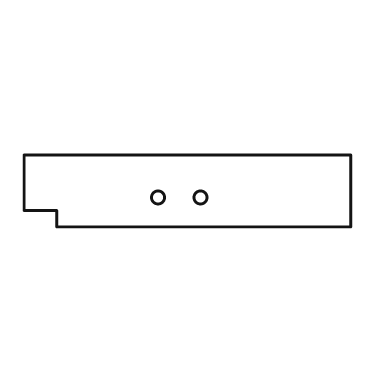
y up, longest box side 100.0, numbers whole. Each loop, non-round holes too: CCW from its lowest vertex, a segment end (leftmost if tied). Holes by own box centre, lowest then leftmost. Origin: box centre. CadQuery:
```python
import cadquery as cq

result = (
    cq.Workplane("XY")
    .moveTo(-40.0, -11.0)
    .lineTo(50.0, -11.0)
    .lineTo(50.0, 11.0)
    .lineTo(-50.0, 11.0)
    .lineTo(-50.0, -6.0)
    .lineTo(-40.0, -6.0)
    .close()
    .moveTo(-9.0, -2.0)
    .circle(2.0)
    .moveTo(4.0, -2.0)
    .circle(2.0)
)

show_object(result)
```